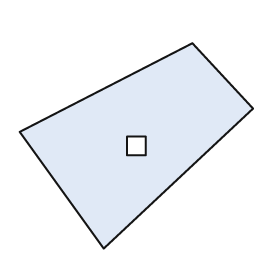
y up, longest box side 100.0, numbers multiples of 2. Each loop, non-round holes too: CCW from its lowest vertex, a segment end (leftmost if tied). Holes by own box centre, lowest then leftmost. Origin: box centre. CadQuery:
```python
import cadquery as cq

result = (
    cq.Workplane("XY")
    .moveTo(-14.0, -44.0)
    .lineTo(50.0, 16.0)
    .lineTo(24.0, 44.0)
    .lineTo(-50.0, 6.0)
    .close()
    .moveTo(-4.0, -4.0)
    .lineTo(4.0, -4.0)
    .lineTo(4.0, 4.0)
    .lineTo(-4.0, 4.0)
    .close()
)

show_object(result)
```